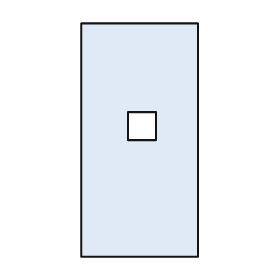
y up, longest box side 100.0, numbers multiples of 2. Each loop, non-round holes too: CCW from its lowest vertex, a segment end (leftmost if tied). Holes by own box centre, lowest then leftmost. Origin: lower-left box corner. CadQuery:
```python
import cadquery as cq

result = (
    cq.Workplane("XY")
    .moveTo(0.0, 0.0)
    .lineTo(50.0, 0.0)
    .lineTo(50.0, 100.0)
    .lineTo(0.0, 100.0)
    .close()
    .moveTo(20.0, 50.0)
    .lineTo(32.0, 50.0)
    .lineTo(32.0, 62.0)
    .lineTo(20.0, 62.0)
    .close()
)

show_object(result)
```